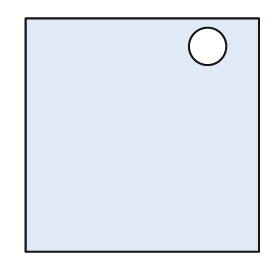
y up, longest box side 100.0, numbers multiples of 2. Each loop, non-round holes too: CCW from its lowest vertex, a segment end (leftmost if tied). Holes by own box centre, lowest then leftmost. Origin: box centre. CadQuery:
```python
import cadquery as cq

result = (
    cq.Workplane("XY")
    .moveTo(-50.0, -50.0)
    .lineTo(50.0, -50.0)
    .lineTo(50.0, 50.0)
    .lineTo(-50.0, 50.0)
    .close()
    .moveTo(28.0, 38.0)
    .circle(8.0)
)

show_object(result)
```